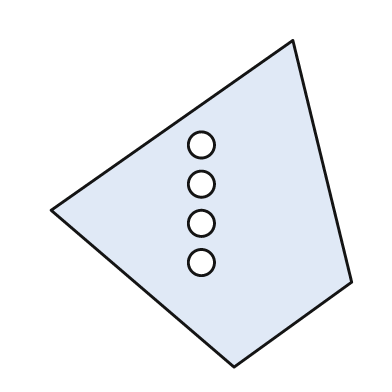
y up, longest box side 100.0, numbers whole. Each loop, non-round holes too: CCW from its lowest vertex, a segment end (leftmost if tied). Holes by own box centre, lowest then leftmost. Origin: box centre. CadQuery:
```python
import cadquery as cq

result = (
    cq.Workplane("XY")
    .moveTo(10.0, -50.0)
    .lineTo(46.0, -24.0)
    .lineTo(28.0, 50.0)
    .lineTo(-46.0, -2.0)
    .close()
    .moveTo(0.0, -18.0)
    .circle(4.0)
    .moveTo(0.0, -6.0)
    .circle(4.0)
    .moveTo(0.0, 6.0)
    .circle(4.0)
    .moveTo(0.0, 18.0)
    .circle(4.0)
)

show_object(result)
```